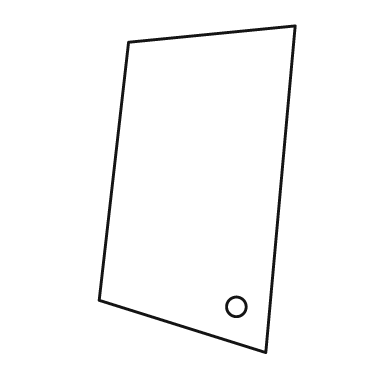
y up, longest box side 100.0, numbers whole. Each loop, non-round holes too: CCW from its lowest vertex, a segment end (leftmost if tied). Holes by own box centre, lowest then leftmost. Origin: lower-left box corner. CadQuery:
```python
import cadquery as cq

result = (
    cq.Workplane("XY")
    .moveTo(51.0, 0.0)
    .lineTo(60.0, 100.0)
    .lineTo(9.0, 95.0)
    .lineTo(0.0, 16.0)
    .close()
    .moveTo(42.0, 14.0)
    .circle(3.0)
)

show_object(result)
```